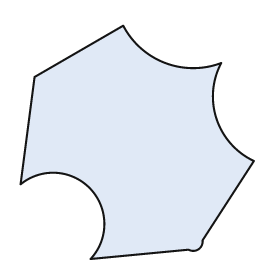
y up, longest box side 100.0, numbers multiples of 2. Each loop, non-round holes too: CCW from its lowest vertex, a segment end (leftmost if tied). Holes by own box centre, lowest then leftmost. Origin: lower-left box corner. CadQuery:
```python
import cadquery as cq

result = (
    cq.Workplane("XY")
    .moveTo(30.0, 0.0)
    .lineTo(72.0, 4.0)
    .threePointArc((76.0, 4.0), (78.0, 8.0))
    .lineTo(100.0, 42.0)
    .threePointArc((84.0, 60.0), (86.0, 84.0))
    .threePointArc((62.0, 84.0), (44.0, 100.0))
    .lineTo(6.0, 78.0)
    .lineTo(0.0, 32.0)
    .threePointArc((30.0, 30.0), (30.0, 0.0))
    .close()
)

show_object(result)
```